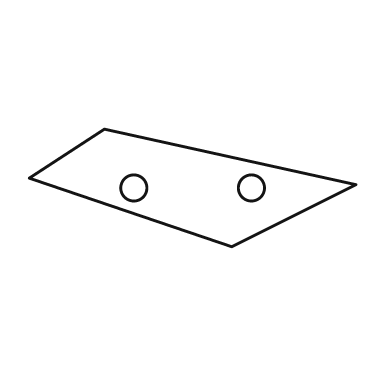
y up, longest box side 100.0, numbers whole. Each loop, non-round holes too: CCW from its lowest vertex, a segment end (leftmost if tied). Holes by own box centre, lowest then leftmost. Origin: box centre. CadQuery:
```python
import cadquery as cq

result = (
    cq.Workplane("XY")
    .moveTo(12.0, -18.0)
    .lineTo(50.0, 1.0)
    .lineTo(-27.0, 18.0)
    .lineTo(-50.0, 3.0)
    .close()
    .moveTo(-18.0, 0.0)
    .circle(4.0)
    .moveTo(18.0, 0.0)
    .circle(4.0)
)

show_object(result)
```